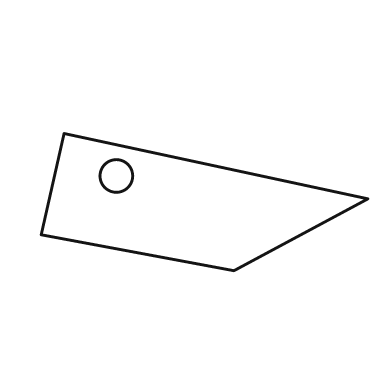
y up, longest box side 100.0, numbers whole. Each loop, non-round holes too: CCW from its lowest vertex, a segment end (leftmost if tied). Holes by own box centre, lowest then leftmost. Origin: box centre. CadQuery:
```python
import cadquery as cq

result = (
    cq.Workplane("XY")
    .moveTo(9.0, -21.0)
    .lineTo(50.0, 1.0)
    .lineTo(-43.0, 21.0)
    .lineTo(-50.0, -10.0)
    .close()
    .moveTo(-27.0, 8.0)
    .circle(5.0)
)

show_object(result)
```